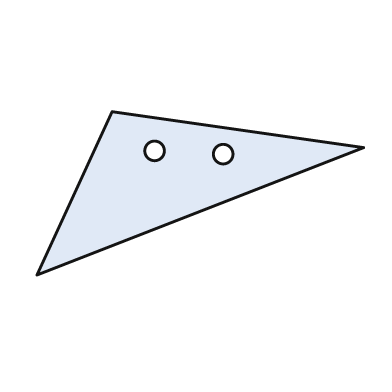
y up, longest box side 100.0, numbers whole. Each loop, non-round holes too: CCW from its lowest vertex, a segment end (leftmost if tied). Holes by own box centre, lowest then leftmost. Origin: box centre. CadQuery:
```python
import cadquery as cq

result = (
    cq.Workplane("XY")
    .moveTo(-50.0, -25.0)
    .lineTo(50.0, 14.0)
    .lineTo(-27.0, 25.0)
    .close()
    .moveTo(7.0, 12.0)
    .circle(3.0)
    .moveTo(-14.0, 13.0)
    .circle(3.0)
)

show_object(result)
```